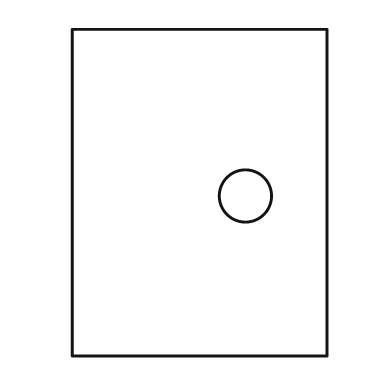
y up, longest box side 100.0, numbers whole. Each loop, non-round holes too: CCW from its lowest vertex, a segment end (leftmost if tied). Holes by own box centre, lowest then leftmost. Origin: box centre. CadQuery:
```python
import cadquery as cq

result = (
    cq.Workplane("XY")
    .moveTo(-39.0, -50.0)
    .lineTo(39.0, -50.0)
    .lineTo(39.0, 50.0)
    .lineTo(-39.0, 50.0)
    .close()
    .moveTo(14.0, -1.0)
    .circle(8.0)
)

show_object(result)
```